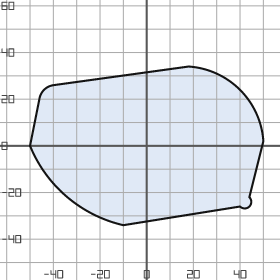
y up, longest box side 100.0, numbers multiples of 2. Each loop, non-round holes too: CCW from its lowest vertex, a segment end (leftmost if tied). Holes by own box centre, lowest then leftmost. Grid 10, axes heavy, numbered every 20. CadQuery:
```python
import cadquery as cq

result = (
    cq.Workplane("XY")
    .moveTo(-10.0, -34.0)
    .lineTo(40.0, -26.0)
    .threePointArc((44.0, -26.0), (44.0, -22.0))
    .lineTo(50.0, 2.0)
    .threePointArc((40.0, 24.0), (18.0, 34.0))
    .lineTo(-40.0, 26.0)
    .threePointArc((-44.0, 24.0), (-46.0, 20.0))
    .lineTo(-50.0, 0.0)
    .threePointArc((-34.0, -22.0), (-10.0, -34.0))
    .close()
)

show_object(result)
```